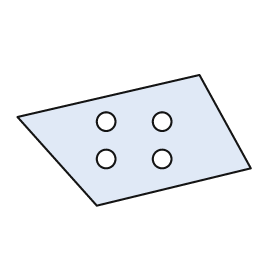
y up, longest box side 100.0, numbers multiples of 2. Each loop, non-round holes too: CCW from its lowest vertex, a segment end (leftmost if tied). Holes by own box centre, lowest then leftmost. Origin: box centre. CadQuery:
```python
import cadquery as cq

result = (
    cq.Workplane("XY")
    .moveTo(-16.0, -28.0)
    .lineTo(50.0, -12.0)
    .lineTo(28.0, 28.0)
    .lineTo(-50.0, 10.0)
    .close()
    .moveTo(-12.0, -8.0)
    .circle(4.0)
    .moveTo(12.0, -8.0)
    .circle(4.0)
    .moveTo(-12.0, 8.0)
    .circle(4.0)
    .moveTo(12.0, 8.0)
    .circle(4.0)
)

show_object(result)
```